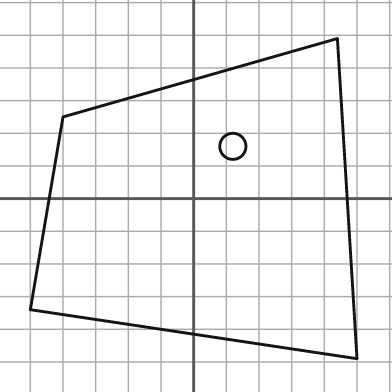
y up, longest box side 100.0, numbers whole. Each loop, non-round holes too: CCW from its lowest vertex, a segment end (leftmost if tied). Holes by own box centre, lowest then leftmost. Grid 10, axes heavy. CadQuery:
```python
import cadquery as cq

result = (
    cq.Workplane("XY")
    .moveTo(50.0, -49.0)
    .lineTo(44.0, 49.0)
    .lineTo(-40.0, 25.0)
    .lineTo(-50.0, -34.0)
    .close()
    .moveTo(12.0, 16.0)
    .circle(4.0)
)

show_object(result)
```